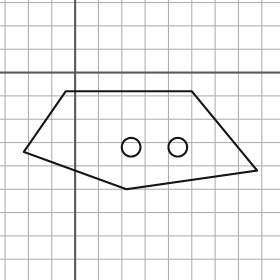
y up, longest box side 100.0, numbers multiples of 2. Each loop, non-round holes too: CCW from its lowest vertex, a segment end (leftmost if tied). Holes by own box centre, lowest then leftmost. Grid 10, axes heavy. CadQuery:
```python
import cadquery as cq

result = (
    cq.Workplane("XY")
    .moveTo(22.0, -50.0)
    .lineTo(78.0, -42.0)
    .lineTo(50.0, -8.0)
    .lineTo(-4.0, -8.0)
    .lineTo(-22.0, -34.0)
    .close()
    .moveTo(24.0, -32.0)
    .circle(4.0)
    .moveTo(44.0, -32.0)
    .circle(4.0)
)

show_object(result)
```